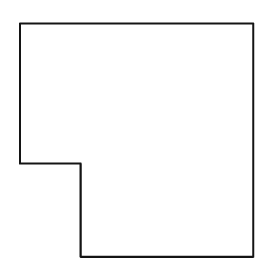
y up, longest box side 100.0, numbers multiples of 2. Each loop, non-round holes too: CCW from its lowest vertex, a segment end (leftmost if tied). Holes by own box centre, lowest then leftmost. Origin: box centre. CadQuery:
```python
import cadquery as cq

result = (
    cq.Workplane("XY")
    .moveTo(-24.0, -50.0)
    .lineTo(50.0, -50.0)
    .lineTo(50.0, 50.0)
    .lineTo(-50.0, 50.0)
    .lineTo(-50.0, -10.0)
    .lineTo(-24.0, -10.0)
    .close()
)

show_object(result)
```